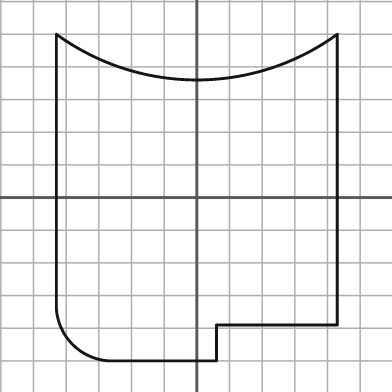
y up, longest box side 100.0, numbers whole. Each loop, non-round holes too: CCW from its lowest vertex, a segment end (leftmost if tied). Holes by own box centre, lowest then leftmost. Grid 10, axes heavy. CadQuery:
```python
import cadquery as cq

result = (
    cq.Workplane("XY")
    .moveTo(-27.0, -50.0)
    .lineTo(6.0, -50.0)
    .lineTo(6.0, -39.0)
    .lineTo(43.0, -39.0)
    .lineTo(43.0, 50.0)
    .threePointArc((0.0, 36.0), (-43.0, 50.0))
    .lineTo(-43.0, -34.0)
    .threePointArc((-38.0, -45.0), (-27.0, -50.0))
    .close()
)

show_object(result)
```